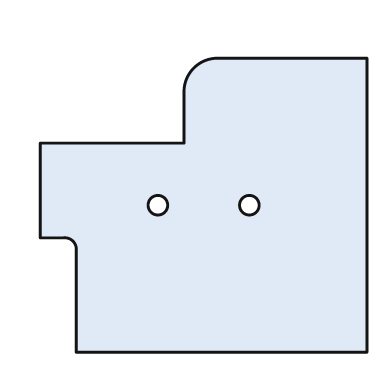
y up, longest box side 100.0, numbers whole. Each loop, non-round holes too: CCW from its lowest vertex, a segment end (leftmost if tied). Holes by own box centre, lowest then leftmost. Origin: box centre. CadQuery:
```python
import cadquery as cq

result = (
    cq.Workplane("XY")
    .moveTo(-39.0, -45.0)
    .lineTo(50.0, -45.0)
    .lineTo(50.0, 45.0)
    .lineTo(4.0, 45.0)
    .threePointArc((-3.0, 42.0), (-6.0, 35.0))
    .lineTo(-6.0, 19.0)
    .lineTo(-50.0, 19.0)
    .lineTo(-50.0, -10.0)
    .lineTo(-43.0, -10.0)
    .threePointArc((-40.0, -11.0), (-39.0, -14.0))
    .close()
    .moveTo(-14.0, 0.0)
    .circle(3.0)
    .moveTo(14.0, 0.0)
    .circle(3.0)
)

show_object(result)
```